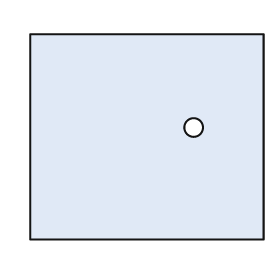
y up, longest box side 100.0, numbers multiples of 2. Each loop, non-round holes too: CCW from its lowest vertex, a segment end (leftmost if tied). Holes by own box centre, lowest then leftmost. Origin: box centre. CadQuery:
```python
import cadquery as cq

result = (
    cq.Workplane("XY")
    .moveTo(-50.0, -44.0)
    .lineTo(50.0, -44.0)
    .lineTo(50.0, 44.0)
    .lineTo(-50.0, 44.0)
    .close()
    .moveTo(20.0, 4.0)
    .circle(4.0)
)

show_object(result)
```